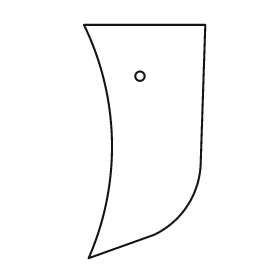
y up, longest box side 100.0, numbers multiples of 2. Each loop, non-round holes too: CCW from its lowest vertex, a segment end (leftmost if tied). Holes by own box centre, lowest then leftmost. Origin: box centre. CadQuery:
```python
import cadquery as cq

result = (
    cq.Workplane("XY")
    .moveTo(-24.0, -50.0)
    .lineTo(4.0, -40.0)
    .threePointArc((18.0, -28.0), (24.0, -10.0))
    .lineTo(26.0, 50.0)
    .lineTo(-26.0, 50.0)
    .threePointArc((-14.0, 0.0), (-24.0, -50.0))
    .close()
    .moveTo(-2.0, 28.0)
    .circle(2.0)
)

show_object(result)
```